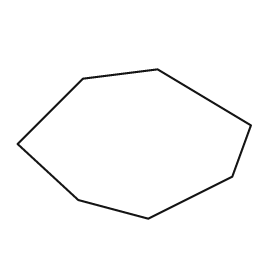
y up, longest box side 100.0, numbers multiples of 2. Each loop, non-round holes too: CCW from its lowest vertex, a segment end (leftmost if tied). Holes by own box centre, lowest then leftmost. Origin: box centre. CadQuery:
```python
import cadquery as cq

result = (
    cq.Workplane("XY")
    .moveTo(6.0, -32.0)
    .lineTo(42.0, -14.0)
    .lineTo(50.0, 8.0)
    .lineTo(10.0, 32.0)
    .lineTo(-22.0, 28.0)
    .lineTo(-50.0, 0.0)
    .lineTo(-24.0, -24.0)
    .close()
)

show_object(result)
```